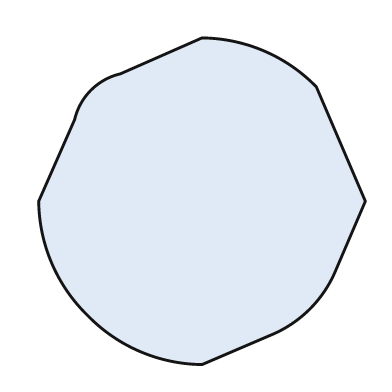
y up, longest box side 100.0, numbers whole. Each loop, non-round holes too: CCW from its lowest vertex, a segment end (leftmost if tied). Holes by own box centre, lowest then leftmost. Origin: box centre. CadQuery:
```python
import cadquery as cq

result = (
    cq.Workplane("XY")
    .moveTo(0.0, -50.0)
    .lineTo(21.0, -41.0)
    .threePointArc((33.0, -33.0), (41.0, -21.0))
    .lineTo(50.0, 0.0)
    .lineTo(35.0, 35.0)
    .threePointArc((19.0, 46.0), (0.0, 50.0))
    .lineTo(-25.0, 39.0)
    .threePointArc((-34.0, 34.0), (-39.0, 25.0))
    .lineTo(-50.0, 0.0)
    .threePointArc((-46.0, -19.0), (-35.0, -35.0))
    .threePointArc((-19.0, -46.0), (0.0, -50.0))
    .close()
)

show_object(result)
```